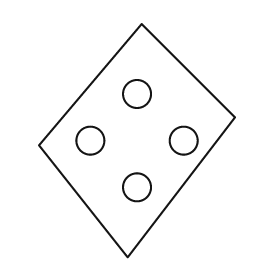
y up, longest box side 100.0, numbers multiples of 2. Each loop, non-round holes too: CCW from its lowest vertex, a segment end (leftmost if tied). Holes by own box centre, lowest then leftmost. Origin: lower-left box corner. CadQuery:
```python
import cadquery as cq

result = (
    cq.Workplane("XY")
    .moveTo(38.0, 0.0)
    .lineTo(84.0, 60.0)
    .lineTo(44.0, 100.0)
    .lineTo(0.0, 48.0)
    .close()
    .moveTo(42.0, 30.0)
    .circle(6.0)
    .moveTo(22.0, 50.0)
    .circle(6.0)
    .moveTo(62.0, 50.0)
    .circle(6.0)
    .moveTo(42.0, 70.0)
    .circle(6.0)
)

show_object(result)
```